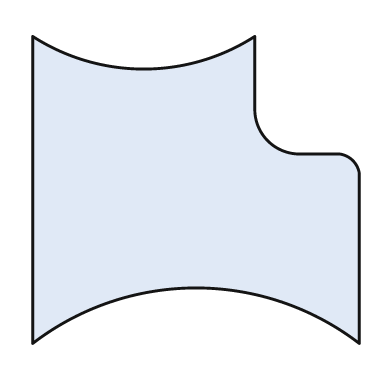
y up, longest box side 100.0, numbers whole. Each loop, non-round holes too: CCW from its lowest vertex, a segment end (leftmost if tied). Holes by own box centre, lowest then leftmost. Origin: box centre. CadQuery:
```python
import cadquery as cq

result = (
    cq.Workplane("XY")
    .moveTo(-50.0, -47.0)
    .threePointArc((0.0, -30.0), (50.0, -47.0))
    .lineTo(50.0, 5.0)
    .threePointArc((48.0, 9.0), (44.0, 11.0))
    .lineTo(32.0, 11.0)
    .threePointArc((22.0, 15.0), (18.0, 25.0))
    .lineTo(18.0, 47.0)
    .threePointArc((-16.0, 37.0), (-50.0, 47.0))
    .close()
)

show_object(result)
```